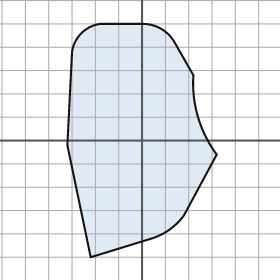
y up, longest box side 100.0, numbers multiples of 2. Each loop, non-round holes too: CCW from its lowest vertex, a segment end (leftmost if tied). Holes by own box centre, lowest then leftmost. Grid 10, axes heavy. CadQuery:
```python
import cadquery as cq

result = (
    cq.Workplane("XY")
    .moveTo(-22.0, -50.0)
    .lineTo(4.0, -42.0)
    .threePointArc((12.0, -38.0), (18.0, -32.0))
    .lineTo(32.0, -6.0)
    .threePointArc((24.0, 10.0), (22.0, 28.0))
    .lineTo(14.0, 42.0)
    .threePointArc((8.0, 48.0), (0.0, 50.0))
    .lineTo(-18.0, 50.0)
    .threePointArc((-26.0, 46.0), (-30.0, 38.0))
    .lineTo(-32.0, -2.0)
    .close()
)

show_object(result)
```